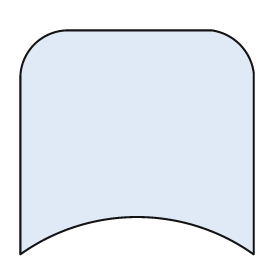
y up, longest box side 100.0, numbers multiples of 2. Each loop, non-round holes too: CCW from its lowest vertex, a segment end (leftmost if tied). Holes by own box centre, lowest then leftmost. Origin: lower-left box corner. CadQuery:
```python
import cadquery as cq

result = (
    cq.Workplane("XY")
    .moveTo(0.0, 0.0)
    .threePointArc((50.0, 16.0), (100.0, 0.0))
    .lineTo(100.0, 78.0)
    .threePointArc((94.0, 90.0), (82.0, 96.0))
    .lineTo(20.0, 96.0)
    .threePointArc((6.0, 90.0), (0.0, 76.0))
    .close()
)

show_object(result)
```